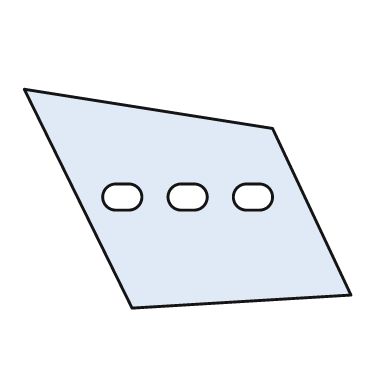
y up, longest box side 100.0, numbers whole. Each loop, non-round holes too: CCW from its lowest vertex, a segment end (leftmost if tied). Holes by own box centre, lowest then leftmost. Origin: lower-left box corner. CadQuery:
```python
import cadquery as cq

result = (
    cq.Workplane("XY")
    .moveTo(33.0, 0.0)
    .lineTo(100.0, 4.0)
    .lineTo(76.0, 55.0)
    .lineTo(0.0, 67.0)
    .close()
    .moveTo(28.0, 30.0)
    .lineTo(32.0, 30.0)
    .threePointArc((36.0, 34.0), (32.0, 38.0))
    .lineTo(28.0, 38.0)
    .threePointArc((24.0, 34.0), (28.0, 30.0))
    .close()
    .moveTo(48.0, 30.0)
    .lineTo(52.0, 30.0)
    .threePointArc((56.0, 34.0), (52.0, 38.0))
    .lineTo(48.0, 38.0)
    .threePointArc((44.0, 34.0), (48.0, 30.0))
    .close()
    .moveTo(68.0, 30.0)
    .lineTo(72.0, 30.0)
    .threePointArc((76.0, 34.0), (72.0, 38.0))
    .lineTo(68.0, 38.0)
    .threePointArc((64.0, 34.0), (68.0, 30.0))
    .close()
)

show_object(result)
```